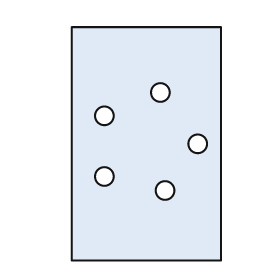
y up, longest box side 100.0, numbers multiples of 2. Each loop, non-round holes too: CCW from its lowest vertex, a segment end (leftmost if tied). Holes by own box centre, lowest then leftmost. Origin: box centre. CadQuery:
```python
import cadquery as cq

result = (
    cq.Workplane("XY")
    .moveTo(-32.0, -50.0)
    .lineTo(32.0, -50.0)
    .lineTo(32.0, 50.0)
    .lineTo(-32.0, 50.0)
    .close()
    .moveTo(8.0, -20.0)
    .circle(4.0)
    .moveTo(-18.0, -14.0)
    .circle(4.0)
    .moveTo(22.0, 0.0)
    .circle(4.0)
    .moveTo(-18.0, 12.0)
    .circle(4.0)
    .moveTo(6.0, 22.0)
    .circle(4.0)
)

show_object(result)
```